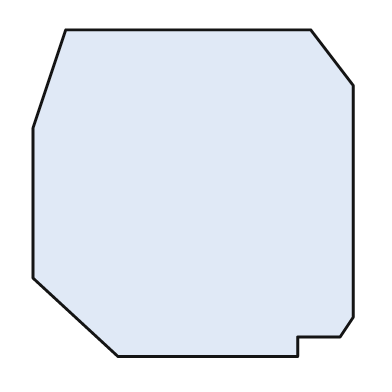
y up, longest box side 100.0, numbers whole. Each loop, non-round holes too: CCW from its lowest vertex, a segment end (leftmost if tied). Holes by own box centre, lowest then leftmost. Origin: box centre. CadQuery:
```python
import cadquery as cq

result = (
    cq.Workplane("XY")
    .moveTo(-23.0, -50.0)
    .lineTo(32.0, -50.0)
    .lineTo(32.0, -44.0)
    .lineTo(45.0, -44.0)
    .lineTo(49.0, -38.0)
    .lineTo(49.0, 33.0)
    .lineTo(36.0, 50.0)
    .lineTo(-39.0, 50.0)
    .lineTo(-49.0, 20.0)
    .lineTo(-49.0, -26.0)
    .close()
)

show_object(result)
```